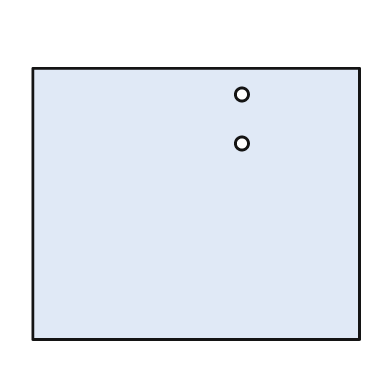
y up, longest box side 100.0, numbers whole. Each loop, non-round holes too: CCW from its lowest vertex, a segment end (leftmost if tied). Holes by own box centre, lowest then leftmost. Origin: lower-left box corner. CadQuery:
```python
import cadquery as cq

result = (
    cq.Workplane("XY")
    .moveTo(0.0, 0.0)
    .lineTo(100.0, 0.0)
    .lineTo(100.0, 83.0)
    .lineTo(0.0, 83.0)
    .close()
    .moveTo(64.0, 60.0)
    .circle(2.0)
    .moveTo(64.0, 75.0)
    .circle(2.0)
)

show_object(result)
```